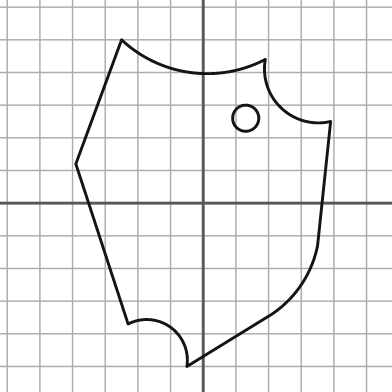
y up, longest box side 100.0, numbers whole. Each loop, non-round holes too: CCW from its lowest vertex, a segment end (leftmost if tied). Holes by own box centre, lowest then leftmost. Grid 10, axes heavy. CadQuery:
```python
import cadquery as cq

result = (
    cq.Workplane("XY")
    .moveTo(-5.0, -50.0)
    .lineTo(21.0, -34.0)
    .threePointArc((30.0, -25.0), (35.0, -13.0))
    .lineTo(39.0, 25.0)
    .threePointArc((24.0, 29.0), (19.0, 44.0))
    .threePointArc((-4.0, 40.0), (-25.0, 50.0))
    .lineTo(-39.0, 12.0)
    .lineTo(-23.0, -37.0)
    .threePointArc((-10.0, -38.0), (-5.0, -50.0))
    .close()
    .moveTo(13.0, 26.0)
    .circle(4.0)
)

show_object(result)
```